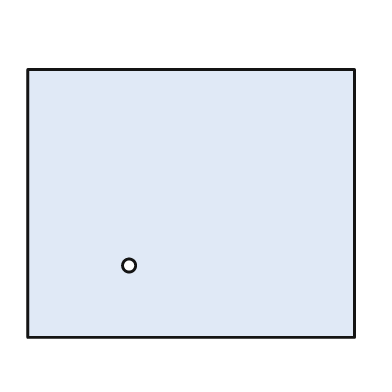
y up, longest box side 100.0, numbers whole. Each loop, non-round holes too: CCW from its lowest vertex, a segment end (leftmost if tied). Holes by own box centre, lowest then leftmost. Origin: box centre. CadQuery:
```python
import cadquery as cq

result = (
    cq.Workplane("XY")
    .moveTo(-50.0, -41.0)
    .lineTo(50.0, -41.0)
    .lineTo(50.0, 41.0)
    .lineTo(-50.0, 41.0)
    .close()
    .moveTo(-19.0, -19.0)
    .circle(2.0)
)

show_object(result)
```